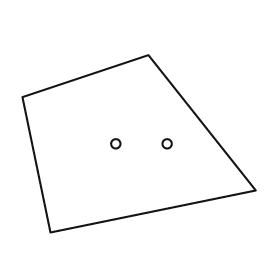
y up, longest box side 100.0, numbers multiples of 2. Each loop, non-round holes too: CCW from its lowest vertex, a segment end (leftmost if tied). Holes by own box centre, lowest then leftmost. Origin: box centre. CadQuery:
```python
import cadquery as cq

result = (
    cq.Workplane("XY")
    .moveTo(-38.0, -38.0)
    .lineTo(50.0, -20.0)
    .lineTo(4.0, 38.0)
    .lineTo(-50.0, 20.0)
    .close()
    .moveTo(-10.0, 0.0)
    .circle(2.0)
    .moveTo(12.0, 0.0)
    .circle(2.0)
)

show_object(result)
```